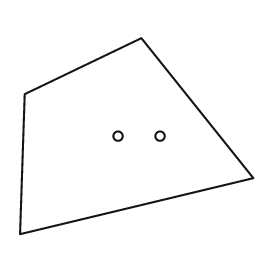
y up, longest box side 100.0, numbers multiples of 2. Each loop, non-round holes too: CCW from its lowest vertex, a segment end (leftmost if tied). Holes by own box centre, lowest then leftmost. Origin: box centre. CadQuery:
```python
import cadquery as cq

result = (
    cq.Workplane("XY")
    .moveTo(-50.0, -42.0)
    .lineTo(50.0, -18.0)
    .lineTo(2.0, 42.0)
    .lineTo(-48.0, 18.0)
    .close()
    .moveTo(-8.0, 0.0)
    .circle(2.0)
    .moveTo(10.0, 0.0)
    .circle(2.0)
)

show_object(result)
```